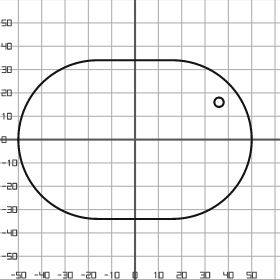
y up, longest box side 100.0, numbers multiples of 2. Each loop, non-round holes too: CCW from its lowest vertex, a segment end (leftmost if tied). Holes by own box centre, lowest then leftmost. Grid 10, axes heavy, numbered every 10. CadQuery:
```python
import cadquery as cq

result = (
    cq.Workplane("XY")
    .moveTo(-16.0, -34.0)
    .lineTo(16.0, -34.0)
    .threePointArc((50.0, 0.0), (16.0, 34.0))
    .lineTo(-16.0, 34.0)
    .threePointArc((-50.0, 0.0), (-16.0, -34.0))
    .close()
    .moveTo(36.0, 16.0)
    .circle(2.0)
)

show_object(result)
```